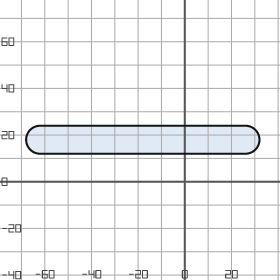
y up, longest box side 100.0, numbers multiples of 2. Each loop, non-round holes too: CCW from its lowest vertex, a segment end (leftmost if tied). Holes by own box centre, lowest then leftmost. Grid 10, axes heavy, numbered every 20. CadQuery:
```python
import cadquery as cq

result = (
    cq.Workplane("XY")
    .moveTo(-62.0, 12.0)
    .lineTo(26.0, 12.0)
    .threePointArc((32.0, 18.0), (26.0, 24.0))
    .lineTo(-62.0, 24.0)
    .threePointArc((-68.0, 18.0), (-62.0, 12.0))
    .close()
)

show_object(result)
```